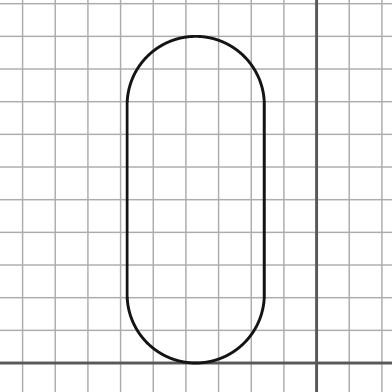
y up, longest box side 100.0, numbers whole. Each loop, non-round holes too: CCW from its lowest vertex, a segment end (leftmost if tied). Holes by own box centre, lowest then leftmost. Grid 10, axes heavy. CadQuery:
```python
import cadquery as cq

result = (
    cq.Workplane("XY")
    .moveTo(-58.0, 21.0)
    .threePointArc((-37.0, 0.0), (-16.0, 21.0))
    .lineTo(-16.0, 79.0)
    .threePointArc((-37.0, 100.0), (-58.0, 79.0))
    .close()
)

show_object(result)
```